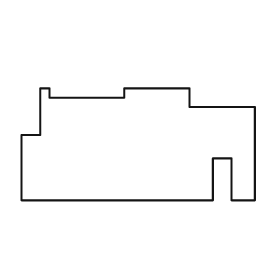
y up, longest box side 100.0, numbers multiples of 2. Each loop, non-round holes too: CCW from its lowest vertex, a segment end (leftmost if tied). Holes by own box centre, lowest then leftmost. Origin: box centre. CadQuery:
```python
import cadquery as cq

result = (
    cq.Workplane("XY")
    .moveTo(-50.0, -24.0)
    .lineTo(32.0, -24.0)
    .lineTo(32.0, -6.0)
    .lineTo(40.0, -6.0)
    .lineTo(40.0, -24.0)
    .lineTo(50.0, -24.0)
    .lineTo(50.0, 16.0)
    .lineTo(22.0, 16.0)
    .lineTo(22.0, 24.0)
    .lineTo(-6.0, 24.0)
    .lineTo(-6.0, 20.0)
    .lineTo(-38.0, 20.0)
    .lineTo(-38.0, 24.0)
    .lineTo(-42.0, 24.0)
    .lineTo(-42.0, 4.0)
    .lineTo(-50.0, 4.0)
    .close()
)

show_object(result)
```